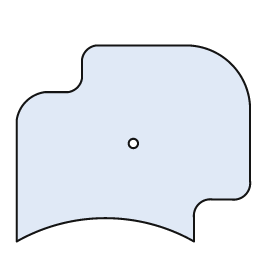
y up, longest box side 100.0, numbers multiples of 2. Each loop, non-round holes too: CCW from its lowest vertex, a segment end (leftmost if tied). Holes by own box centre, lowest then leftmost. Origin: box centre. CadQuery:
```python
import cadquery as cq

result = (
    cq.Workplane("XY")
    .moveTo(-50.0, -42.0)
    .threePointArc((-12.0, -32.0), (26.0, -42.0))
    .lineTo(26.0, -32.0)
    .threePointArc((28.0, -26.0), (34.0, -24.0))
    .lineTo(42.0, -24.0)
    .threePointArc((48.0, -22.0), (50.0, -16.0))
    .lineTo(50.0, 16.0)
    .threePointArc((42.0, 34.0), (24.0, 42.0))
    .lineTo(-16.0, 42.0)
    .threePointArc((-20.0, 40.0), (-22.0, 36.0))
    .lineTo(-22.0, 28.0)
    .threePointArc((-24.0, 24.0), (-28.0, 22.0))
    .lineTo(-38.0, 22.0)
    .threePointArc((-46.0, 18.0), (-50.0, 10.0))
    .close()
    .moveTo(0.0, 0.0)
    .circle(2.0)
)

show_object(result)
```